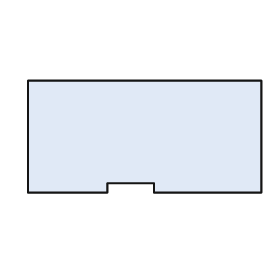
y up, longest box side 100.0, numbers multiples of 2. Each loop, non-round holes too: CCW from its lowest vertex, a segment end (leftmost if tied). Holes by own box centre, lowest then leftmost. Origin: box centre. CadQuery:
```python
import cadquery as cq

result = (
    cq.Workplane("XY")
    .moveTo(-50.0, -24.0)
    .lineTo(-16.0, -24.0)
    .lineTo(-16.0, -20.0)
    .lineTo(4.0, -20.0)
    .lineTo(4.0, -24.0)
    .lineTo(50.0, -24.0)
    .lineTo(50.0, 24.0)
    .lineTo(-50.0, 24.0)
    .close()
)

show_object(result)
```